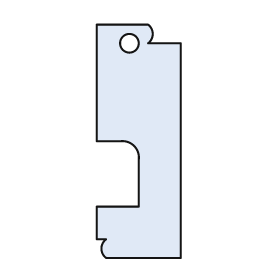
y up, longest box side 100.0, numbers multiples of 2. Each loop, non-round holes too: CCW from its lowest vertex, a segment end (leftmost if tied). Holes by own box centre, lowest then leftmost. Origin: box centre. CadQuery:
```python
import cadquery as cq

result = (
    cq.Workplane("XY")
    .moveTo(-14.0, -50.0)
    .lineTo(18.0, -50.0)
    .lineTo(18.0, 42.0)
    .lineTo(4.0, 42.0)
    .threePointArc((6.0, 46.0), (4.0, 50.0))
    .lineTo(-18.0, 50.0)
    .lineTo(-18.0, 0.0)
    .lineTo(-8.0, 0.0)
    .threePointArc((-2.0, -2.0), (0.0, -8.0))
    .lineTo(0.0, -28.0)
    .lineTo(-18.0, -28.0)
    .lineTo(-18.0, -42.0)
    .lineTo(-14.0, -42.0)
    .threePointArc((-16.0, -46.0), (-14.0, -50.0))
    .close()
    .moveTo(-4.0, 42.0)
    .circle(4.0)
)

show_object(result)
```